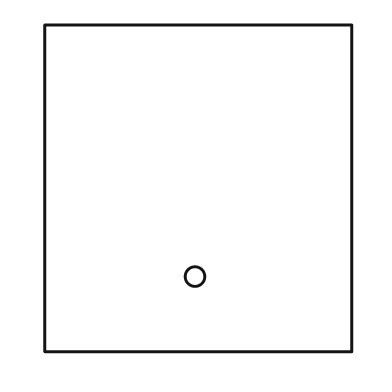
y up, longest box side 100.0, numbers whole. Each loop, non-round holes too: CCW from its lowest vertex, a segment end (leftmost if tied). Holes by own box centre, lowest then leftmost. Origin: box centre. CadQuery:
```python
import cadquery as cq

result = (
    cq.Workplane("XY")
    .moveTo(-47.0, -50.0)
    .lineTo(47.0, -50.0)
    .lineTo(47.0, 50.0)
    .lineTo(-47.0, 50.0)
    .close()
    .moveTo(-1.0, -27.0)
    .circle(3.0)
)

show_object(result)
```